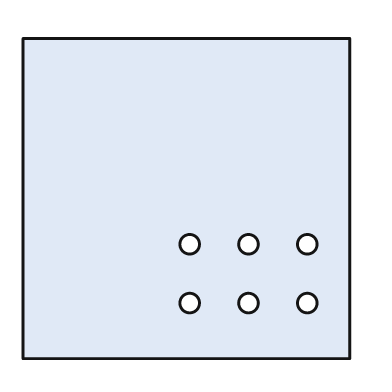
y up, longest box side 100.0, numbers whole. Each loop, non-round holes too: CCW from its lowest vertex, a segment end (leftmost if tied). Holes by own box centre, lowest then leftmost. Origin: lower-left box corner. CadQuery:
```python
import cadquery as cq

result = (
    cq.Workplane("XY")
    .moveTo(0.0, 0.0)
    .lineTo(100.0, 0.0)
    .lineTo(100.0, 98.0)
    .lineTo(0.0, 98.0)
    .close()
    .moveTo(51.0, 17.0)
    .circle(3.0)
    .moveTo(69.0, 17.0)
    .circle(3.0)
    .moveTo(87.0, 17.0)
    .circle(3.0)
    .moveTo(51.0, 35.0)
    .circle(3.0)
    .moveTo(69.0, 35.0)
    .circle(3.0)
    .moveTo(87.0, 35.0)
    .circle(3.0)
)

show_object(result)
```